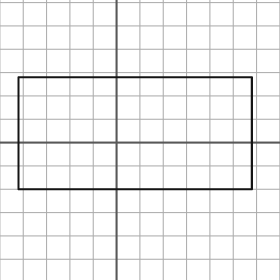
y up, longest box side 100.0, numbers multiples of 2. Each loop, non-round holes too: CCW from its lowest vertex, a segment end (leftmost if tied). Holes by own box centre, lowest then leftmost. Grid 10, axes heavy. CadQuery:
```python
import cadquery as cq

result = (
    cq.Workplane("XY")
    .moveTo(-42.0, -20.0)
    .lineTo(58.0, -20.0)
    .lineTo(58.0, 28.0)
    .lineTo(-42.0, 28.0)
    .close()
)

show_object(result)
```